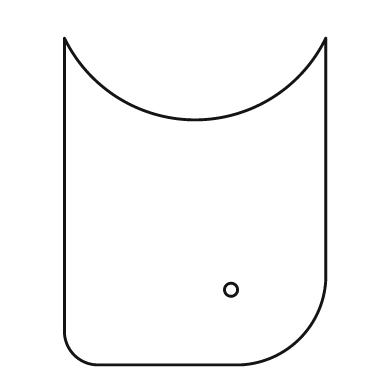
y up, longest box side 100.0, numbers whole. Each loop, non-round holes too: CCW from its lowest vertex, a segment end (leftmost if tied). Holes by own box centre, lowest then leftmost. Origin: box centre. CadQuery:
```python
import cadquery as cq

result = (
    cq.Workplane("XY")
    .moveTo(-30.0, -50.0)
    .lineTo(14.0, -50.0)
    .threePointArc((32.0, -42.0), (40.0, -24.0))
    .lineTo(40.0, 50.0)
    .threePointArc((0.0, 25.0), (-40.0, 50.0))
    .lineTo(-40.0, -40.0)
    .threePointArc((-37.0, -47.0), (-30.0, -50.0))
    .close()
    .moveTo(11.0, -27.0)
    .circle(2.0)
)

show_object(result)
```